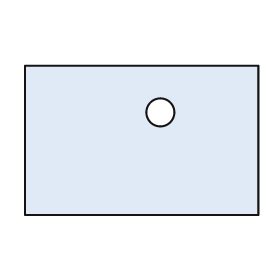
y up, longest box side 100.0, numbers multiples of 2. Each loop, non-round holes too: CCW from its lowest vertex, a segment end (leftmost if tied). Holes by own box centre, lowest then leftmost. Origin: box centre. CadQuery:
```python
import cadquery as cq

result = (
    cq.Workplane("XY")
    .moveTo(-50.0, -32.0)
    .lineTo(50.0, -32.0)
    .lineTo(50.0, 32.0)
    .lineTo(-50.0, 32.0)
    .close()
    .moveTo(8.0, 12.0)
    .circle(6.0)
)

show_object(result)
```